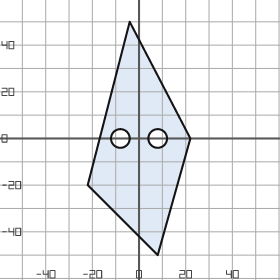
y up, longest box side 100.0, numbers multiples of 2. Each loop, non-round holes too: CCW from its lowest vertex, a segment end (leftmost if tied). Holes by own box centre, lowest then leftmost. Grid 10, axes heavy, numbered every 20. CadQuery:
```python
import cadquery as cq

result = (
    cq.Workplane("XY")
    .moveTo(8.0, -50.0)
    .lineTo(22.0, 0.0)
    .lineTo(-4.0, 50.0)
    .lineTo(-22.0, -20.0)
    .close()
    .moveTo(-8.0, 0.0)
    .circle(4.0)
    .moveTo(8.0, 0.0)
    .circle(4.0)
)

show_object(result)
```